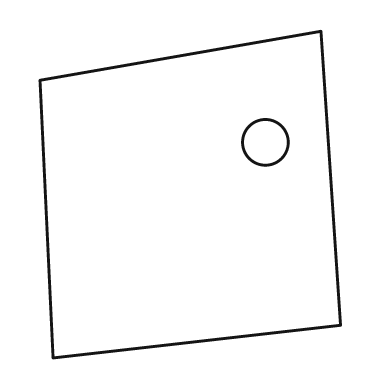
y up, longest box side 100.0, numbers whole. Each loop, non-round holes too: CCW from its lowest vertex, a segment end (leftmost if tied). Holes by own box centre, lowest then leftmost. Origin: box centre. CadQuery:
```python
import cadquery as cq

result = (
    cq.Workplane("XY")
    .moveTo(-42.0, -50.0)
    .lineTo(46.0, -40.0)
    .lineTo(40.0, 50.0)
    .lineTo(-46.0, 35.0)
    .close()
    .moveTo(23.0, 16.0)
    .circle(7.0)
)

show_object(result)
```